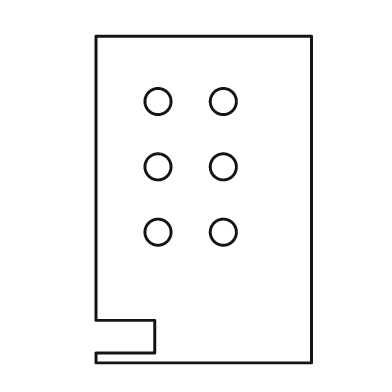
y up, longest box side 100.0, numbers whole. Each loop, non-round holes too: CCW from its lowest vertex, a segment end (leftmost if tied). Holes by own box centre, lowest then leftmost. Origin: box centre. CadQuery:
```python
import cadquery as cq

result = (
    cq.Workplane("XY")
    .moveTo(-33.0, -50.0)
    .lineTo(33.0, -50.0)
    .lineTo(33.0, 50.0)
    .lineTo(-33.0, 50.0)
    .lineTo(-33.0, -37.0)
    .lineTo(-15.0, -37.0)
    .lineTo(-15.0, -47.0)
    .lineTo(-33.0, -47.0)
    .close()
    .moveTo(-14.0, -10.0)
    .circle(4.0)
    .moveTo(6.0, -10.0)
    .circle(4.0)
    .moveTo(-14.0, 10.0)
    .circle(4.0)
    .moveTo(6.0, 10.0)
    .circle(4.0)
    .moveTo(-14.0, 30.0)
    .circle(4.0)
    .moveTo(6.0, 30.0)
    .circle(4.0)
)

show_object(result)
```